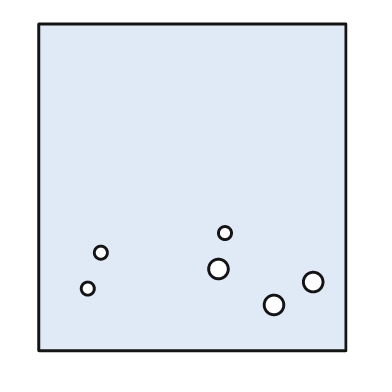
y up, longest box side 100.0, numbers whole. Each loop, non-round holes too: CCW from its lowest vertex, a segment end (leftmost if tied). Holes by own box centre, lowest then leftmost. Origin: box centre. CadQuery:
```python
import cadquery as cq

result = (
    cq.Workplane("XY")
    .moveTo(-47.0, -50.0)
    .lineTo(47.0, -50.0)
    .lineTo(47.0, 50.0)
    .lineTo(-47.0, 50.0)
    .close()
    .moveTo(25.0, -36.0)
    .circle(3.0)
    .moveTo(-32.0, -31.0)
    .circle(2.0)
    .moveTo(37.0, -29.0)
    .circle(3.0)
    .moveTo(8.0, -25.0)
    .circle(3.0)
    .moveTo(-28.0, -20.0)
    .circle(2.0)
    .moveTo(10.0, -14.0)
    .circle(2.0)
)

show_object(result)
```